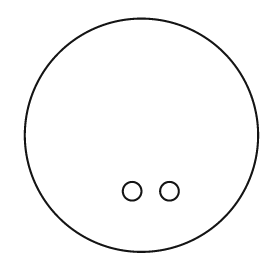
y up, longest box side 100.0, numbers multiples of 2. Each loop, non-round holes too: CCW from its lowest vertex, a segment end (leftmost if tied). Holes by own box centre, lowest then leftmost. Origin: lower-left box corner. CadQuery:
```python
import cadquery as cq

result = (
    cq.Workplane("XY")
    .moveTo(50.0, 50.0)
    .circle(50.0)
    .moveTo(46.0, 26.0)
    .circle(4.0)
    .moveTo(62.0, 26.0)
    .circle(4.0)
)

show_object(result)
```